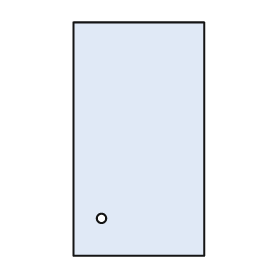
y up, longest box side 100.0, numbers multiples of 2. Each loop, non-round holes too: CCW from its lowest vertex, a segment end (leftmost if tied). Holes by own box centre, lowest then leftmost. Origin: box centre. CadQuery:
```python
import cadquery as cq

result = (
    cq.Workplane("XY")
    .moveTo(-28.0, -50.0)
    .lineTo(28.0, -50.0)
    .lineTo(28.0, 50.0)
    .lineTo(-28.0, 50.0)
    .close()
    .moveTo(-16.0, -34.0)
    .circle(2.0)
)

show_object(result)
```